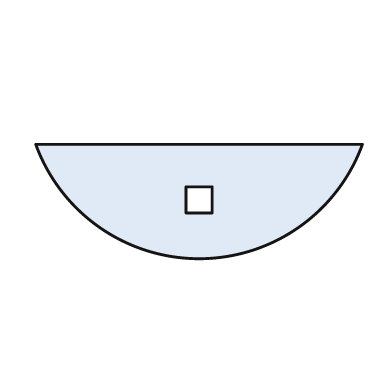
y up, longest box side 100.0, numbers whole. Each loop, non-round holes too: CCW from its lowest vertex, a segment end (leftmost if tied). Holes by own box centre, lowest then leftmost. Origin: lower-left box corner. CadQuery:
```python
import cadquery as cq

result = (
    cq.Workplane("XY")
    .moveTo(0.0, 35.0)
    .threePointArc((50.0, 0.0), (100.0, 35.0))
    .close()
    .moveTo(46.0, 14.0)
    .lineTo(54.0, 14.0)
    .lineTo(54.0, 22.0)
    .lineTo(46.0, 22.0)
    .close()
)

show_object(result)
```